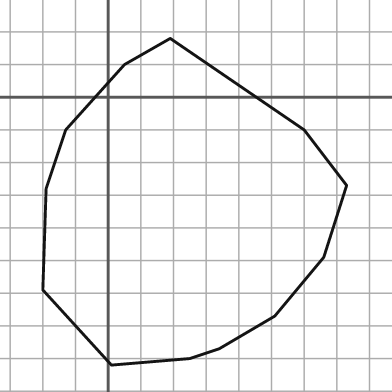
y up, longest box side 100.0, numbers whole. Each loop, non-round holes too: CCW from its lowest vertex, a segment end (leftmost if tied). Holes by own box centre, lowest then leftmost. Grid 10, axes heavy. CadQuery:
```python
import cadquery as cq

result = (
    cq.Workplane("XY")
    .moveTo(1.0, -82.0)
    .lineTo(25.0, -80.0)
    .lineTo(34.0, -77.0)
    .lineTo(51.0, -67.0)
    .lineTo(66.0, -49.0)
    .lineTo(73.0, -27.0)
    .lineTo(60.0, -10.0)
    .lineTo(19.0, 18.0)
    .lineTo(5.0, 10.0)
    .lineTo(-13.0, -10.0)
    .lineTo(-19.0, -28.0)
    .lineTo(-20.0, -59.0)
    .close()
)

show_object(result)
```